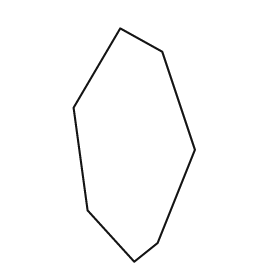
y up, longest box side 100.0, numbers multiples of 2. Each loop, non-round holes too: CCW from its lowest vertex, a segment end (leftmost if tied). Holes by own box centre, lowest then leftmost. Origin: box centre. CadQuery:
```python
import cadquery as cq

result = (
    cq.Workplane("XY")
    .moveTo(0.0, -50.0)
    .lineTo(10.0, -42.0)
    .lineTo(26.0, -2.0)
    .lineTo(12.0, 40.0)
    .lineTo(-6.0, 50.0)
    .lineTo(-26.0, 16.0)
    .lineTo(-20.0, -28.0)
    .close()
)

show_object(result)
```